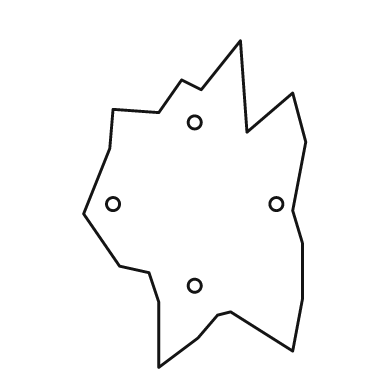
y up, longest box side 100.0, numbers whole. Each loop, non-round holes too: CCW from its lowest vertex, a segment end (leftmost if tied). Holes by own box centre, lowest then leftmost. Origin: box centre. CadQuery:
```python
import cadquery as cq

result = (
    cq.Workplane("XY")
    .moveTo(-11.0, -50.0)
    .lineTo(1.0, -41.0)
    .lineTo(7.0, -34.0)
    .lineTo(11.0, -33.0)
    .lineTo(30.0, -45.0)
    .lineTo(33.0, -29.0)
    .lineTo(33.0, -12.0)
    .lineTo(30.0, -2.0)
    .lineTo(34.0, 19.0)
    .lineTo(30.0, 34.0)
    .lineTo(16.0, 22.0)
    .lineTo(14.0, 50.0)
    .lineTo(2.0, 35.0)
    .lineTo(-4.0, 38.0)
    .lineTo(-11.0, 28.0)
    .lineTo(-25.0, 29.0)
    .lineTo(-26.0, 17.0)
    .lineTo(-34.0, -3.0)
    .lineTo(-23.0, -19.0)
    .lineTo(-14.0, -21.0)
    .lineTo(-11.0, -30.0)
    .close()
    .moveTo(0.0, -25.0)
    .circle(2.0)
    .moveTo(-25.0, 0.0)
    .circle(2.0)
    .moveTo(25.0, 0.0)
    .circle(2.0)
    .moveTo(0.0, 25.0)
    .circle(2.0)
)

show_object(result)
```